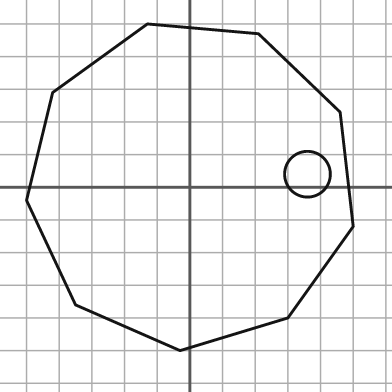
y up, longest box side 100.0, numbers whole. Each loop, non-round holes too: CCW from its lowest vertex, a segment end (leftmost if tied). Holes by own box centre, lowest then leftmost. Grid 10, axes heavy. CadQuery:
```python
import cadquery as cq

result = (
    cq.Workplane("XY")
    .moveTo(-3.0, -50.0)
    .lineTo(30.0, -40.0)
    .lineTo(50.0, -12.0)
    .lineTo(46.0, 23.0)
    .lineTo(21.0, 47.0)
    .lineTo(-13.0, 50.0)
    .lineTo(-42.0, 29.0)
    .lineTo(-50.0, -4.0)
    .lineTo(-35.0, -36.0)
    .close()
    .moveTo(36.0, 4.0)
    .circle(7.0)
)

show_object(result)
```